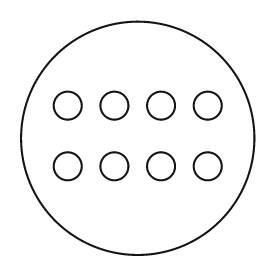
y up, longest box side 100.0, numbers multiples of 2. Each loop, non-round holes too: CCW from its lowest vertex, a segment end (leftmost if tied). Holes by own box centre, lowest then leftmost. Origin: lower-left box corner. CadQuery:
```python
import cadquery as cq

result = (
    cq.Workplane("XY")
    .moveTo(50.0, 50.0)
    .circle(50.0)
    .moveTo(20.0, 38.0)
    .circle(6.0)
    .moveTo(40.0, 38.0)
    .circle(6.0)
    .moveTo(60.0, 38.0)
    .circle(6.0)
    .moveTo(80.0, 38.0)
    .circle(6.0)
    .moveTo(20.0, 64.0)
    .circle(6.0)
    .moveTo(40.0, 64.0)
    .circle(6.0)
    .moveTo(60.0, 64.0)
    .circle(6.0)
    .moveTo(80.0, 64.0)
    .circle(6.0)
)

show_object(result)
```